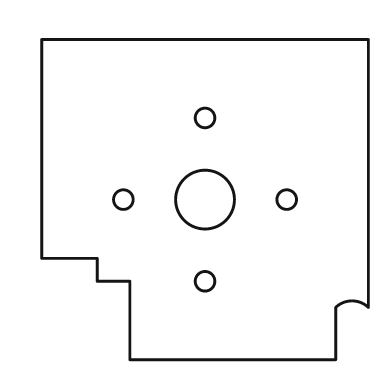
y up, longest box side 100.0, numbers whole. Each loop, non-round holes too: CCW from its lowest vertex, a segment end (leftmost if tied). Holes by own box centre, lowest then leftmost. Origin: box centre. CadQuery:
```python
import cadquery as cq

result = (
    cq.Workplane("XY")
    .moveTo(-23.0, -49.0)
    .lineTo(40.0, -49.0)
    .lineTo(40.0, -33.0)
    .threePointArc((45.0, -31.0), (50.0, -33.0))
    .lineTo(50.0, 49.0)
    .lineTo(-50.0, 49.0)
    .lineTo(-50.0, -18.0)
    .lineTo(-33.0, -18.0)
    .lineTo(-33.0, -25.0)
    .lineTo(-23.0, -25.0)
    .close()
    .moveTo(0.0, -25.0)
    .circle(3.0)
    .moveTo(-25.0, 0.0)
    .circle(3.0)
    .moveTo(0.0, 0.0)
    .circle(9.0)
    .moveTo(25.0, 0.0)
    .circle(3.0)
    .moveTo(0.0, 25.0)
    .circle(3.0)
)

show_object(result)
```